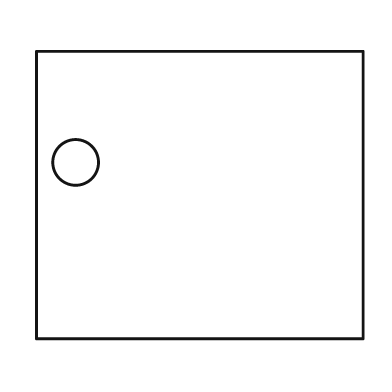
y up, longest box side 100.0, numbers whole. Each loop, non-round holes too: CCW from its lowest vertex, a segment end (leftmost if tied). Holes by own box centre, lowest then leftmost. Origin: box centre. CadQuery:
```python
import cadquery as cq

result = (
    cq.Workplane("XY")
    .moveTo(-50.0, -44.0)
    .lineTo(50.0, -44.0)
    .lineTo(50.0, 44.0)
    .lineTo(-50.0, 44.0)
    .close()
    .moveTo(-38.0, 10.0)
    .circle(7.0)
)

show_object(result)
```